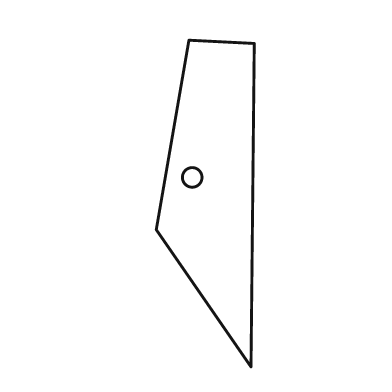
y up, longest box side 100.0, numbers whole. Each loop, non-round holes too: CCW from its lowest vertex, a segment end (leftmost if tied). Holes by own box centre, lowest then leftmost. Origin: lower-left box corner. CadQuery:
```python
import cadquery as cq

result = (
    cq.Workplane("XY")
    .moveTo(29.0, 0.0)
    .lineTo(30.0, 99.0)
    .lineTo(10.0, 100.0)
    .lineTo(0.0, 42.0)
    .close()
    .moveTo(11.0, 58.0)
    .circle(3.0)
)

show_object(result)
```